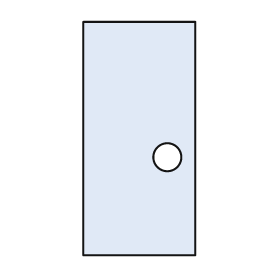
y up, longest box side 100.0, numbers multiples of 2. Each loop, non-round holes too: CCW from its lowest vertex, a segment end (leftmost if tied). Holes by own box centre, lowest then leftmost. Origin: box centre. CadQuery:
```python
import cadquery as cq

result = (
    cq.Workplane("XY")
    .moveTo(-24.0, -50.0)
    .lineTo(24.0, -50.0)
    .lineTo(24.0, 50.0)
    .lineTo(-24.0, 50.0)
    .close()
    .moveTo(12.0, -8.0)
    .circle(6.0)
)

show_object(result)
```